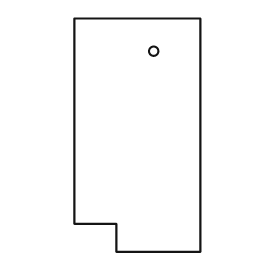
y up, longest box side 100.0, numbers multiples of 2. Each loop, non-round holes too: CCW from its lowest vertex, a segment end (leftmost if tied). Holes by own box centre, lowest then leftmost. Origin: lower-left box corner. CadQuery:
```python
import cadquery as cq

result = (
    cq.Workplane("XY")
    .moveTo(18.0, 0.0)
    .lineTo(54.0, 0.0)
    .lineTo(54.0, 100.0)
    .lineTo(0.0, 100.0)
    .lineTo(0.0, 12.0)
    .lineTo(18.0, 12.0)
    .close()
    .moveTo(34.0, 86.0)
    .circle(2.0)
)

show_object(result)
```